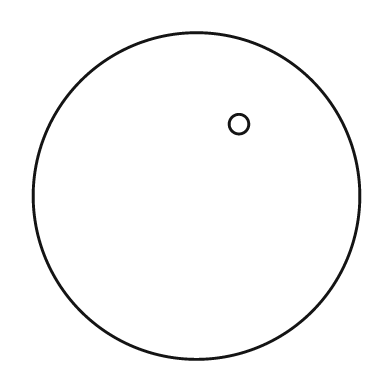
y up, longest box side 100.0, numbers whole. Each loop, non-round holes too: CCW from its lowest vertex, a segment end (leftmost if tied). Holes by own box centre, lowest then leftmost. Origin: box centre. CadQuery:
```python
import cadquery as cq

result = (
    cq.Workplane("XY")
    .moveTo(0.0, 0.0)
    .circle(50.0)
    .moveTo(13.0, 22.0)
    .circle(3.0)
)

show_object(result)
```